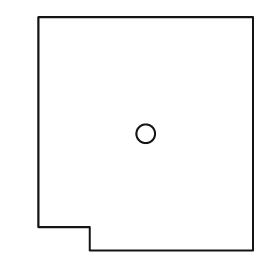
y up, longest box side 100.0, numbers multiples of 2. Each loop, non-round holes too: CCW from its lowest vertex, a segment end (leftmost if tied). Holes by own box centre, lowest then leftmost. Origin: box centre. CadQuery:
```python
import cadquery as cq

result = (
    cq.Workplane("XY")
    .moveTo(-24.0, -50.0)
    .lineTo(46.0, -50.0)
    .lineTo(46.0, 50.0)
    .lineTo(-46.0, 50.0)
    .lineTo(-46.0, -40.0)
    .lineTo(-24.0, -40.0)
    .close()
    .moveTo(0.0, 0.0)
    .circle(4.0)
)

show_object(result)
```